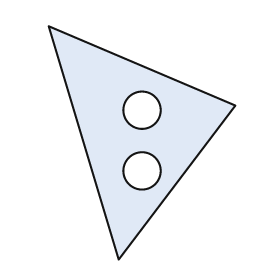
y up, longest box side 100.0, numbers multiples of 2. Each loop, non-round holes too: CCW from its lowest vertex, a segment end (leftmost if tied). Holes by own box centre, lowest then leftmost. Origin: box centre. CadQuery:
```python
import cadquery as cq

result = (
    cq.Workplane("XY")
    .moveTo(-10.0, -50.0)
    .lineTo(40.0, 16.0)
    .lineTo(-40.0, 50.0)
    .close()
    .moveTo(0.0, -12.0)
    .circle(8.0)
    .moveTo(0.0, 14.0)
    .circle(8.0)
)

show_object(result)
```